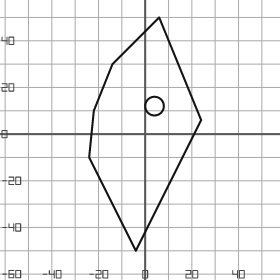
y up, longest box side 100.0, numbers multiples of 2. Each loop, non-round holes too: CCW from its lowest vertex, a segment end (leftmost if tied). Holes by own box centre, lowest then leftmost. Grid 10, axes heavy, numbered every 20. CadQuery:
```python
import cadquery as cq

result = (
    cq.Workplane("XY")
    .moveTo(-4.0, -50.0)
    .lineTo(24.0, 6.0)
    .lineTo(6.0, 50.0)
    .lineTo(-14.0, 30.0)
    .lineTo(-22.0, 10.0)
    .lineTo(-24.0, -10.0)
    .close()
    .moveTo(4.0, 12.0)
    .circle(4.0)
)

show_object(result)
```